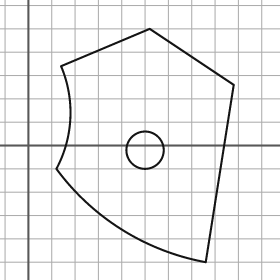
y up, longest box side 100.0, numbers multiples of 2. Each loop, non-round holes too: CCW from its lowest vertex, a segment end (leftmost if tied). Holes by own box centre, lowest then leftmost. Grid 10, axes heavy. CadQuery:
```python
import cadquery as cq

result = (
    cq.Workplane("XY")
    .moveTo(76.0, -50.0)
    .lineTo(88.0, 26.0)
    .lineTo(52.0, 50.0)
    .lineTo(14.0, 34.0)
    .threePointArc((18.0, 12.0), (12.0, -10.0))
    .threePointArc((40.0, -36.0), (76.0, -50.0))
    .close()
    .moveTo(50.0, -2.0)
    .circle(8.0)
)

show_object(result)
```